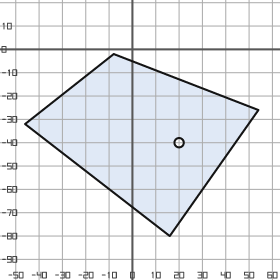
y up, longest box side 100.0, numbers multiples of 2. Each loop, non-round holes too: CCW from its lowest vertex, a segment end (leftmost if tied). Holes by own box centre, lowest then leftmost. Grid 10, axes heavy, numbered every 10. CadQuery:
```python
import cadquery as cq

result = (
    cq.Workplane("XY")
    .moveTo(16.0, -80.0)
    .lineTo(54.0, -26.0)
    .lineTo(-8.0, -2.0)
    .lineTo(-46.0, -32.0)
    .close()
    .moveTo(20.0, -40.0)
    .circle(2.0)
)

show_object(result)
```